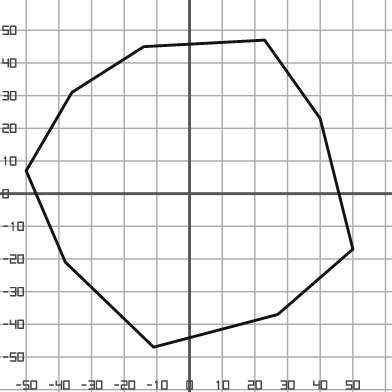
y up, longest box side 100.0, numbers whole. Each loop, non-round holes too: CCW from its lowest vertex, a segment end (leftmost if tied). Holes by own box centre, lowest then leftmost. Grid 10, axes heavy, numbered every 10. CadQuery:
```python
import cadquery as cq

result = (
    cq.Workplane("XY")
    .moveTo(-11.0, -47.0)
    .lineTo(27.0, -37.0)
    .lineTo(50.0, -17.0)
    .lineTo(40.0, 23.0)
    .lineTo(23.0, 47.0)
    .lineTo(-14.0, 45.0)
    .lineTo(-36.0, 31.0)
    .lineTo(-50.0, 7.0)
    .lineTo(-38.0, -21.0)
    .close()
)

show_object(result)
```